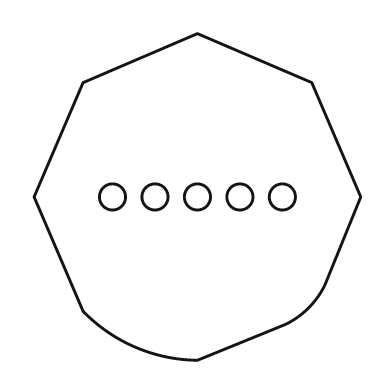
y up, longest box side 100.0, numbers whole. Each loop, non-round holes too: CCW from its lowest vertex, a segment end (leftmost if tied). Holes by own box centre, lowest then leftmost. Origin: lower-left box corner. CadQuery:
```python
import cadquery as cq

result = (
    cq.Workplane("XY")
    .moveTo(50.0, 0.0)
    .lineTo(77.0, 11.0)
    .threePointArc((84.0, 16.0), (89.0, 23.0))
    .lineTo(100.0, 50.0)
    .lineTo(85.0, 85.0)
    .lineTo(50.0, 100.0)
    .lineTo(15.0, 85.0)
    .lineTo(0.0, 50.0)
    .lineTo(15.0, 15.0)
    .threePointArc((31.0, 4.0), (50.0, 0.0))
    .close()
    .moveTo(24.0, 50.0)
    .circle(4.0)
    .moveTo(37.0, 50.0)
    .circle(4.0)
    .moveTo(50.0, 50.0)
    .circle(4.0)
    .moveTo(63.0, 50.0)
    .circle(4.0)
    .moveTo(76.0, 50.0)
    .circle(4.0)
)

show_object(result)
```